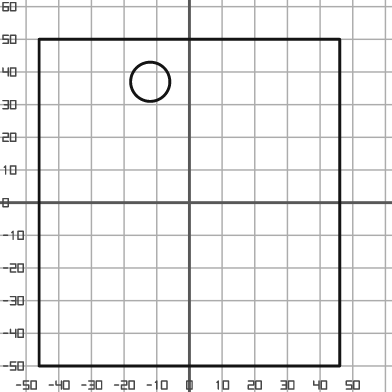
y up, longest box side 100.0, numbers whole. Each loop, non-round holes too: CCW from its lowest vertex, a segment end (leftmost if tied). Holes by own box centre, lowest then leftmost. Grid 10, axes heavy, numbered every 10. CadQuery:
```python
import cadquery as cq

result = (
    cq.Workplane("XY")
    .moveTo(-46.0, -50.0)
    .lineTo(46.0, -50.0)
    .lineTo(46.0, 50.0)
    .lineTo(-46.0, 50.0)
    .close()
    .moveTo(-12.0, 37.0)
    .circle(6.0)
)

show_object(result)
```